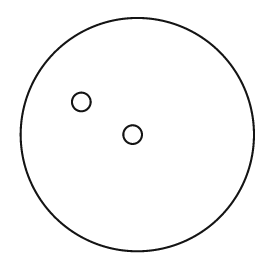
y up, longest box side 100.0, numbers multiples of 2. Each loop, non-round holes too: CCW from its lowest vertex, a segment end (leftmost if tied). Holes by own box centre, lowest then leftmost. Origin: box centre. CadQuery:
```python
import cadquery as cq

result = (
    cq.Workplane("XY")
    .moveTo(0.0, 0.0)
    .circle(50.0)
    .moveTo(-2.0, 0.0)
    .circle(4.0)
    .moveTo(-24.0, 14.0)
    .circle(4.0)
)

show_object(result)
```